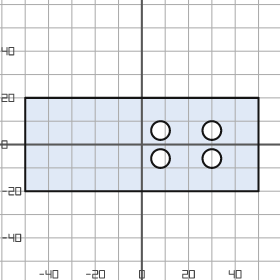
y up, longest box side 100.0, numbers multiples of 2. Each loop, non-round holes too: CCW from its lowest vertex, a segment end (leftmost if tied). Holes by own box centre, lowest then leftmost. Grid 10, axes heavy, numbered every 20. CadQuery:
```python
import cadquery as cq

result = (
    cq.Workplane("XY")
    .moveTo(-50.0, -20.0)
    .lineTo(50.0, -20.0)
    .lineTo(50.0, 20.0)
    .lineTo(-50.0, 20.0)
    .close()
    .moveTo(8.0, -6.0)
    .circle(4.0)
    .moveTo(30.0, -6.0)
    .circle(4.0)
    .moveTo(8.0, 6.0)
    .circle(4.0)
    .moveTo(30.0, 6.0)
    .circle(4.0)
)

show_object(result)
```